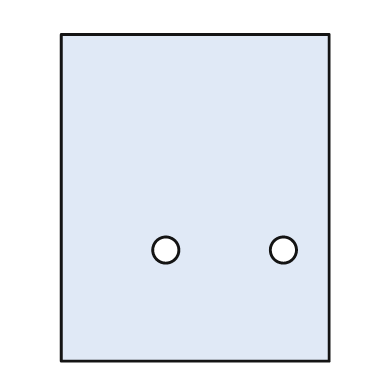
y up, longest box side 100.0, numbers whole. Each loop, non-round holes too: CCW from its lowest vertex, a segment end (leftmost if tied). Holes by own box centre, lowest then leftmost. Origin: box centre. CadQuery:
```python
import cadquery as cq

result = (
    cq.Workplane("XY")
    .moveTo(-41.0, -50.0)
    .lineTo(41.0, -50.0)
    .lineTo(41.0, 50.0)
    .lineTo(-41.0, 50.0)
    .close()
    .moveTo(-9.0, -16.0)
    .circle(4.0)
    .moveTo(27.0, -16.0)
    .circle(4.0)
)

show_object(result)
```